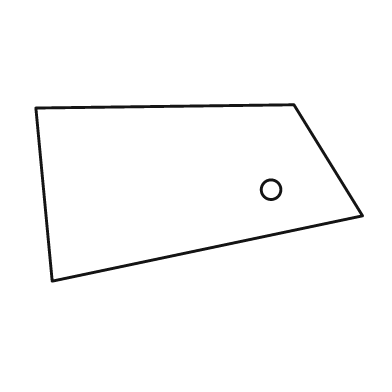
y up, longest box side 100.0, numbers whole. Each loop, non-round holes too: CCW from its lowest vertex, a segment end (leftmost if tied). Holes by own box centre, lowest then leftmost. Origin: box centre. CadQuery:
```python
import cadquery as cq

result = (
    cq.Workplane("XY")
    .moveTo(-45.0, -27.0)
    .lineTo(50.0, -7.0)
    .lineTo(29.0, 27.0)
    .lineTo(-50.0, 26.0)
    .close()
    .moveTo(22.0, 1.0)
    .circle(3.0)
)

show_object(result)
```